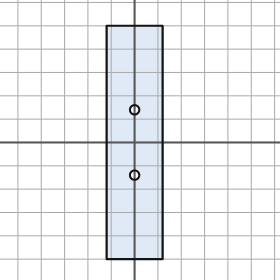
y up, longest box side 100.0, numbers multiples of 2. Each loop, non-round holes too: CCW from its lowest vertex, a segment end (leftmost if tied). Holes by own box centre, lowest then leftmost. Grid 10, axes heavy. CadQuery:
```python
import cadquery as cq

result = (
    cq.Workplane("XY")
    .moveTo(-12.0, -50.0)
    .lineTo(12.0, -50.0)
    .lineTo(12.0, 50.0)
    .lineTo(-12.0, 50.0)
    .close()
    .moveTo(0.0, -14.0)
    .circle(2.0)
    .moveTo(0.0, 14.0)
    .circle(2.0)
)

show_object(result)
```